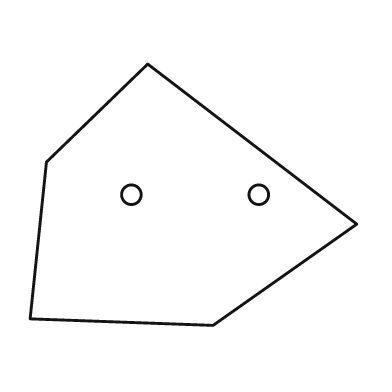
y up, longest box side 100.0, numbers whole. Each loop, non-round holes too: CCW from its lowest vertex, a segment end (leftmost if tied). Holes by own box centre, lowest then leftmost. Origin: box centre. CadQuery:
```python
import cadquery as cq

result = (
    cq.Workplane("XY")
    .moveTo(6.0, -40.0)
    .lineTo(50.0, -9.0)
    .lineTo(-14.0, 40.0)
    .lineTo(-45.0, 10.0)
    .lineTo(-50.0, -38.0)
    .close()
    .moveTo(-19.0, 0.0)
    .circle(3.0)
    .moveTo(20.0, 0.0)
    .circle(3.0)
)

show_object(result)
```